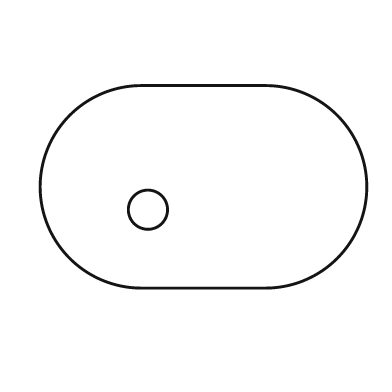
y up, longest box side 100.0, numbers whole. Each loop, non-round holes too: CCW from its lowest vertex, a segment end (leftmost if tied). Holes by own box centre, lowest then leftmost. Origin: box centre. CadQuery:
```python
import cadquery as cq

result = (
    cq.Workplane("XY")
    .moveTo(-19.0, -31.0)
    .lineTo(19.0, -31.0)
    .threePointArc((50.0, 0.0), (19.0, 31.0))
    .lineTo(-19.0, 31.0)
    .threePointArc((-50.0, 0.0), (-19.0, -31.0))
    .close()
    .moveTo(-17.0, -7.0)
    .circle(6.0)
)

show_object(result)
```